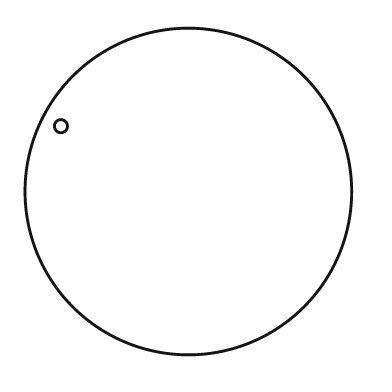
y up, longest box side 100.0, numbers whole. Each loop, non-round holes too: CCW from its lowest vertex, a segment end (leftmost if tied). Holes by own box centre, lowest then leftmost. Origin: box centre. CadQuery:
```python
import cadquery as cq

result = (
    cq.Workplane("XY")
    .moveTo(0.0, 0.0)
    .circle(50.0)
    .moveTo(-39.0, 20.0)
    .circle(2.0)
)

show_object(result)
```